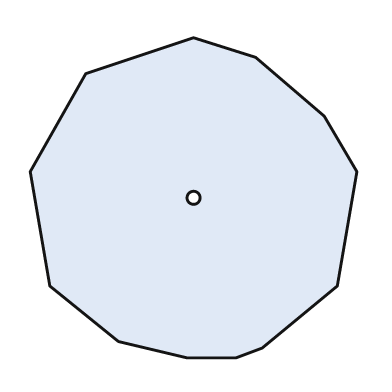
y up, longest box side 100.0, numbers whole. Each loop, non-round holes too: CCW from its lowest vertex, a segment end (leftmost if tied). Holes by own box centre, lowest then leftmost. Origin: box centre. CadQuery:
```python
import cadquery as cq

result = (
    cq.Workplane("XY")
    .moveTo(-2.0, -49.0)
    .lineTo(13.0, -49.0)
    .lineTo(21.0, -46.0)
    .lineTo(44.0, -27.0)
    .lineTo(50.0, 8.0)
    .lineTo(40.0, 25.0)
    .lineTo(19.0, 43.0)
    .lineTo(0.0, 49.0)
    .lineTo(-33.0, 38.0)
    .lineTo(-50.0, 8.0)
    .lineTo(-44.0, -27.0)
    .lineTo(-23.0, -44.0)
    .close()
    .moveTo(0.0, 0.0)
    .circle(2.0)
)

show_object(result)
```